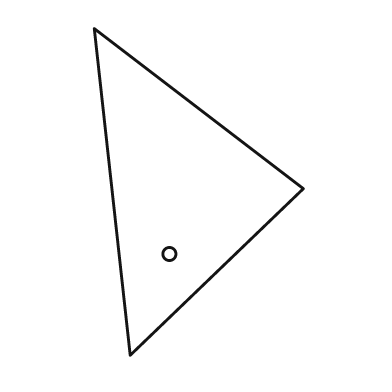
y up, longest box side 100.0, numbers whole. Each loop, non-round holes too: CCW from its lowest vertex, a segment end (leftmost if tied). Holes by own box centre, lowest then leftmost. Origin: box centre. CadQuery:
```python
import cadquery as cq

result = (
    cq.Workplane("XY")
    .moveTo(-21.0, -50.0)
    .lineTo(32.0, 1.0)
    .lineTo(-32.0, 50.0)
    .close()
    .moveTo(-9.0, -19.0)
    .circle(2.0)
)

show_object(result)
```